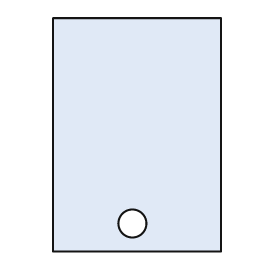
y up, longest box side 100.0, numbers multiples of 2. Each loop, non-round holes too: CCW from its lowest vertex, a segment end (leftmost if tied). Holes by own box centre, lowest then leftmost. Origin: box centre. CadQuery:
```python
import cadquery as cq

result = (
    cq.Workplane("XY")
    .moveTo(-36.0, -50.0)
    .lineTo(36.0, -50.0)
    .lineTo(36.0, 50.0)
    .lineTo(-36.0, 50.0)
    .close()
    .moveTo(-2.0, -38.0)
    .circle(6.0)
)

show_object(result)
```